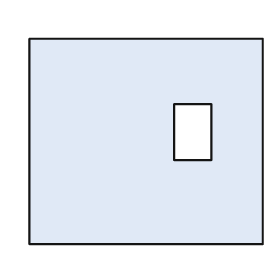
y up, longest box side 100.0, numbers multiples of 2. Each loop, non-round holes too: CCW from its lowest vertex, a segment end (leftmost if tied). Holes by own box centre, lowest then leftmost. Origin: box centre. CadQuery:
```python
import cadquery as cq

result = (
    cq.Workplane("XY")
    .moveTo(-50.0, -44.0)
    .lineTo(50.0, -44.0)
    .lineTo(50.0, 44.0)
    .lineTo(-50.0, 44.0)
    .close()
    .moveTo(12.0, -8.0)
    .lineTo(28.0, -8.0)
    .lineTo(28.0, 16.0)
    .lineTo(12.0, 16.0)
    .close()
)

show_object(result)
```